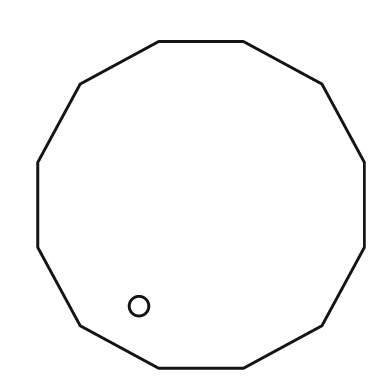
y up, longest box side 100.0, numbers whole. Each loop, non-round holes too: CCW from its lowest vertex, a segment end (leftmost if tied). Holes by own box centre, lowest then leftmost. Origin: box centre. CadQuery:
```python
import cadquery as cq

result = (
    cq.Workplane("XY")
    .moveTo(-13.0, -50.0)
    .lineTo(13.0, -50.0)
    .lineTo(37.0, -37.0)
    .lineTo(50.0, -13.0)
    .lineTo(50.0, 13.0)
    .lineTo(37.0, 37.0)
    .lineTo(13.0, 50.0)
    .lineTo(-13.0, 50.0)
    .lineTo(-37.0, 37.0)
    .lineTo(-50.0, 13.0)
    .lineTo(-50.0, -13.0)
    .lineTo(-37.0, -37.0)
    .close()
    .moveTo(-19.0, -31.0)
    .circle(3.0)
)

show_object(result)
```